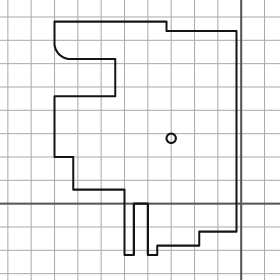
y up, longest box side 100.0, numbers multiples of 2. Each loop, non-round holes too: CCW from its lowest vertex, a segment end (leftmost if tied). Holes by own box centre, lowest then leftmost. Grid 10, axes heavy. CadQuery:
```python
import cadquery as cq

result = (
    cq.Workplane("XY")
    .moveTo(-50.0, -22.0)
    .lineTo(-46.0, -22.0)
    .lineTo(-46.0, 0.0)
    .lineTo(-40.0, 0.0)
    .lineTo(-40.0, -22.0)
    .lineTo(-36.0, -22.0)
    .lineTo(-36.0, -18.0)
    .lineTo(-18.0, -18.0)
    .lineTo(-18.0, -12.0)
    .lineTo(-2.0, -12.0)
    .lineTo(-2.0, 74.0)
    .lineTo(-32.0, 74.0)
    .lineTo(-32.0, 78.0)
    .lineTo(-80.0, 78.0)
    .lineTo(-80.0, 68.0)
    .threePointArc((-78.0, 64.0), (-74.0, 62.0))
    .lineTo(-54.0, 62.0)
    .lineTo(-54.0, 46.0)
    .lineTo(-80.0, 46.0)
    .lineTo(-80.0, 20.0)
    .lineTo(-72.0, 20.0)
    .lineTo(-72.0, 6.0)
    .lineTo(-50.0, 6.0)
    .close()
    .moveTo(-30.0, 28.0)
    .circle(2.0)
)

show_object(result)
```